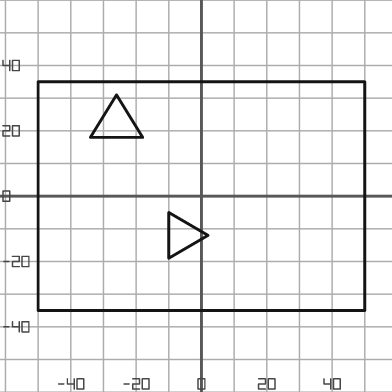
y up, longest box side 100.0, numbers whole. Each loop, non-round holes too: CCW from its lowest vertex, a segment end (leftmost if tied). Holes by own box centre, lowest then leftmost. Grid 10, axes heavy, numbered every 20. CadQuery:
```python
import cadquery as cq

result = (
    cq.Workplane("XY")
    .moveTo(-50.0, -35.0)
    .lineTo(50.0, -35.0)
    .lineTo(50.0, 35.0)
    .lineTo(-50.0, 35.0)
    .close()
    .moveTo(-10.0, -19.0)
    .lineTo(2.0, -12.0)
    .lineTo(-10.0, -5.0)
    .close()
    .moveTo(-34.0, 18.0)
    .lineTo(-18.0, 18.0)
    .lineTo(-26.0, 31.0)
    .close()
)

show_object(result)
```